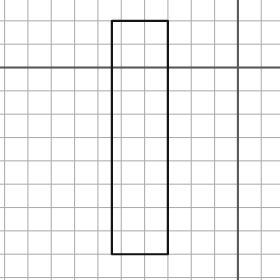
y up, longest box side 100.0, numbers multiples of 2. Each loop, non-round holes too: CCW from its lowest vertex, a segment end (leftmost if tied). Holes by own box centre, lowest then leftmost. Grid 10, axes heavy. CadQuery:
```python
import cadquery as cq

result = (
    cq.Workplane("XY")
    .moveTo(-54.0, -80.0)
    .lineTo(-30.0, -80.0)
    .lineTo(-30.0, 20.0)
    .lineTo(-54.0, 20.0)
    .close()
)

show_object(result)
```